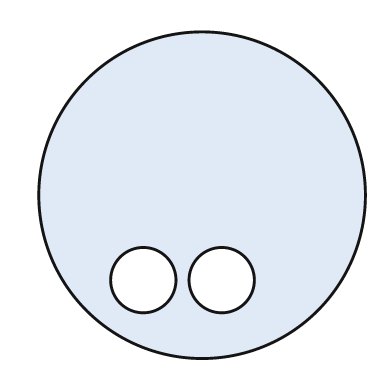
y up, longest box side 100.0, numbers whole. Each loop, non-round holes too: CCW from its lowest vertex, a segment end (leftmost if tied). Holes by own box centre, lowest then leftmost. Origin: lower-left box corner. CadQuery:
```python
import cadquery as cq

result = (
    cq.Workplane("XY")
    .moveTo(50.0, 50.0)
    .circle(50.0)
    .moveTo(32.0, 24.0)
    .circle(10.0)
    .moveTo(56.0, 24.0)
    .circle(10.0)
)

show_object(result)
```